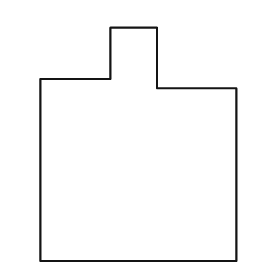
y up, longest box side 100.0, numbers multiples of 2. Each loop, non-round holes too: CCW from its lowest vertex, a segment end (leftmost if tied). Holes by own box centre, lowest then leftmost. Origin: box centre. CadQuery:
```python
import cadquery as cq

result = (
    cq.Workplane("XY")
    .moveTo(-42.0, -50.0)
    .lineTo(42.0, -50.0)
    .lineTo(42.0, 24.0)
    .lineTo(8.0, 24.0)
    .lineTo(8.0, 50.0)
    .lineTo(-12.0, 50.0)
    .lineTo(-12.0, 28.0)
    .lineTo(-42.0, 28.0)
    .close()
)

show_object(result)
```